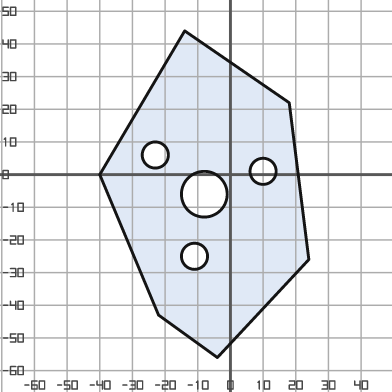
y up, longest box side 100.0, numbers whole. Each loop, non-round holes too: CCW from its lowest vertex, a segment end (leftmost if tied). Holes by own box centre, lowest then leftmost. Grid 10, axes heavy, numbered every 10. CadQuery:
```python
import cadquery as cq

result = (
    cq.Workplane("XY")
    .moveTo(-4.0, -56.0)
    .lineTo(24.0, -26.0)
    .lineTo(18.0, 22.0)
    .lineTo(-14.0, 44.0)
    .lineTo(-40.0, 0.0)
    .lineTo(-22.0, -43.0)
    .close()
    .moveTo(-11.0, -25.0)
    .circle(4.0)
    .moveTo(-8.0, -6.0)
    .circle(7.0)
    .moveTo(10.0, 1.0)
    .circle(4.0)
    .moveTo(-23.0, 6.0)
    .circle(4.0)
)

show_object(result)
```